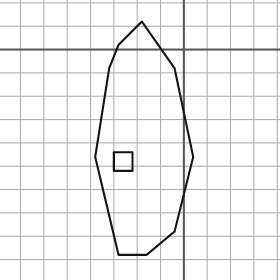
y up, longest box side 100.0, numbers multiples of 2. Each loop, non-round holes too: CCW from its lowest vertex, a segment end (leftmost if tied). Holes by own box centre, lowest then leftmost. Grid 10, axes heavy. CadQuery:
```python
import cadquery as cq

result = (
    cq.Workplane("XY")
    .moveTo(-28.0, -88.0)
    .lineTo(-16.0, -88.0)
    .lineTo(-4.0, -78.0)
    .lineTo(4.0, -46.0)
    .lineTo(-4.0, -8.0)
    .lineTo(-18.0, 12.0)
    .lineTo(-28.0, 2.0)
    .lineTo(-32.0, -8.0)
    .lineTo(-38.0, -46.0)
    .close()
    .moveTo(-30.0, -52.0)
    .lineTo(-22.0, -52.0)
    .lineTo(-22.0, -44.0)
    .lineTo(-30.0, -44.0)
    .close()
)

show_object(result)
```